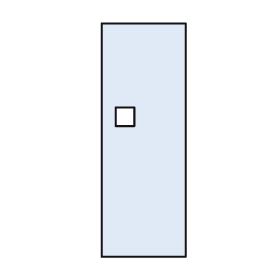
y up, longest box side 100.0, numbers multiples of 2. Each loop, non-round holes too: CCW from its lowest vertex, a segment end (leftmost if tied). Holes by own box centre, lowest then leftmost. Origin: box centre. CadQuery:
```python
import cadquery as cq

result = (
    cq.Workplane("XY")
    .moveTo(-18.0, -50.0)
    .lineTo(18.0, -50.0)
    .lineTo(18.0, 50.0)
    .lineTo(-18.0, 50.0)
    .close()
    .moveTo(-12.0, 6.0)
    .lineTo(-4.0, 6.0)
    .lineTo(-4.0, 14.0)
    .lineTo(-12.0, 14.0)
    .close()
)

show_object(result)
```